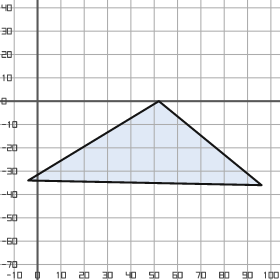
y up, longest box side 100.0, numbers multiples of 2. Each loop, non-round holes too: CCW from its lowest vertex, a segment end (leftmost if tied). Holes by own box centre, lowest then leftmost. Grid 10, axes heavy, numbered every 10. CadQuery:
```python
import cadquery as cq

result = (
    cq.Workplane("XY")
    .moveTo(96.0, -36.0)
    .lineTo(52.0, 0.0)
    .lineTo(-4.0, -34.0)
    .close()
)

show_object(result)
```